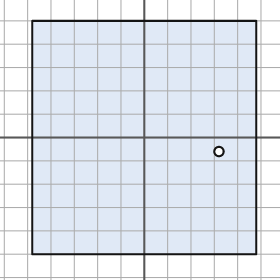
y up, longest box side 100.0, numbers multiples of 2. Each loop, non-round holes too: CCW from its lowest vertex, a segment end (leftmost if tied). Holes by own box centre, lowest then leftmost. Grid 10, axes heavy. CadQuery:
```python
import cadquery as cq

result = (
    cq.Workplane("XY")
    .moveTo(-48.0, -50.0)
    .lineTo(48.0, -50.0)
    .lineTo(48.0, 50.0)
    .lineTo(-48.0, 50.0)
    .close()
    .moveTo(32.0, -6.0)
    .circle(2.0)
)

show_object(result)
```